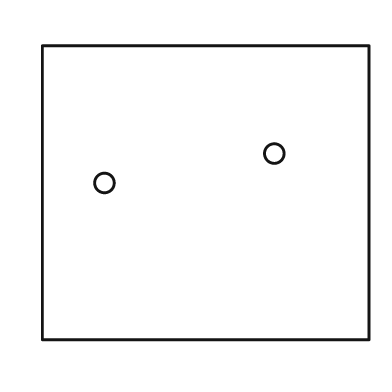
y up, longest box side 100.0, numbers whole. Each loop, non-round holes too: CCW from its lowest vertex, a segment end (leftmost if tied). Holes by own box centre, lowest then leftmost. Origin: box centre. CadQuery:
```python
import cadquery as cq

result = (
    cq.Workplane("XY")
    .moveTo(-50.0, -45.0)
    .lineTo(50.0, -45.0)
    .lineTo(50.0, 45.0)
    .lineTo(-50.0, 45.0)
    .close()
    .moveTo(-31.0, 3.0)
    .circle(3.0)
    .moveTo(21.0, 12.0)
    .circle(3.0)
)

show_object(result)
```